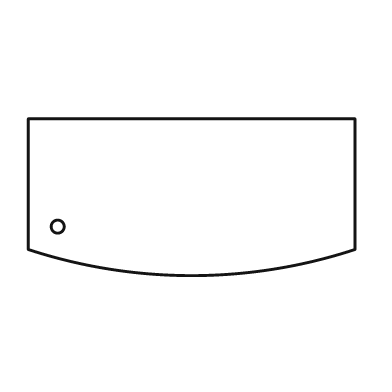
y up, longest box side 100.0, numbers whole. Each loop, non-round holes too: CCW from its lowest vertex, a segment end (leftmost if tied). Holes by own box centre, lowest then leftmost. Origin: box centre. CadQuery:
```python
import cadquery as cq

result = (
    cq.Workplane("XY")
    .moveTo(-50.0, -16.0)
    .threePointArc((0.0, -24.0), (50.0, -16.0))
    .lineTo(50.0, 24.0)
    .lineTo(-50.0, 24.0)
    .close()
    .moveTo(-41.0, -9.0)
    .circle(2.0)
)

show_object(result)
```